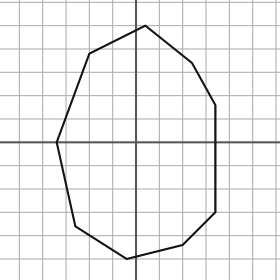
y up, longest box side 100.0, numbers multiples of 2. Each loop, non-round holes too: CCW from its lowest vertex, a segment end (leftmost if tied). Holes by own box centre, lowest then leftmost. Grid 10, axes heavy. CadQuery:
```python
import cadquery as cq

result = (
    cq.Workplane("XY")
    .moveTo(-4.0, -50.0)
    .lineTo(20.0, -44.0)
    .lineTo(34.0, -30.0)
    .lineTo(34.0, 16.0)
    .lineTo(24.0, 34.0)
    .lineTo(4.0, 50.0)
    .lineTo(-20.0, 38.0)
    .lineTo(-34.0, 0.0)
    .lineTo(-26.0, -36.0)
    .close()
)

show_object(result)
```